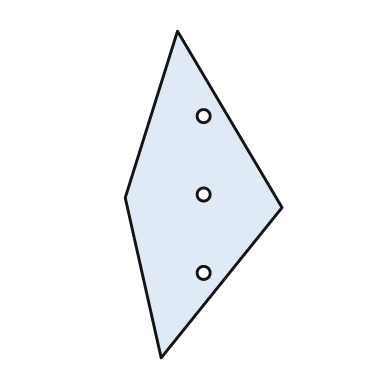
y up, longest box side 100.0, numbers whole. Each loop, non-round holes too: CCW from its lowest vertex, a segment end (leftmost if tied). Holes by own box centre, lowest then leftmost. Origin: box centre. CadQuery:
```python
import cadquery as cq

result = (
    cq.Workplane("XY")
    .moveTo(-13.0, -50.0)
    .lineTo(24.0, -4.0)
    .lineTo(-8.0, 50.0)
    .lineTo(-24.0, -1.0)
    .close()
    .moveTo(0.0, -24.0)
    .circle(2.0)
    .moveTo(0.0, 0.0)
    .circle(2.0)
    .moveTo(0.0, 24.0)
    .circle(2.0)
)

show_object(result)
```